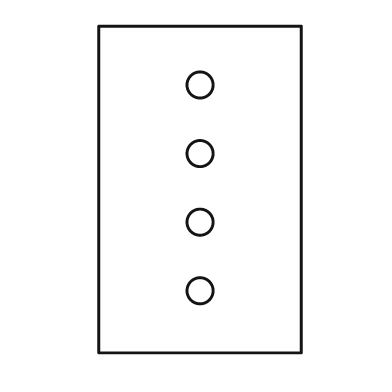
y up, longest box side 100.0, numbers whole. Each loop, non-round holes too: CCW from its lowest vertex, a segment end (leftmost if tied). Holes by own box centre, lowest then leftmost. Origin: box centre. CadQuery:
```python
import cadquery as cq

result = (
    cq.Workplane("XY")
    .moveTo(-31.0, -50.0)
    .lineTo(31.0, -50.0)
    .lineTo(31.0, 50.0)
    .lineTo(-31.0, 50.0)
    .close()
    .moveTo(0.0, -31.0)
    .circle(4.0)
    .moveTo(0.0, -10.0)
    .circle(4.0)
    .moveTo(0.0, 11.0)
    .circle(4.0)
    .moveTo(0.0, 32.0)
    .circle(4.0)
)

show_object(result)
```